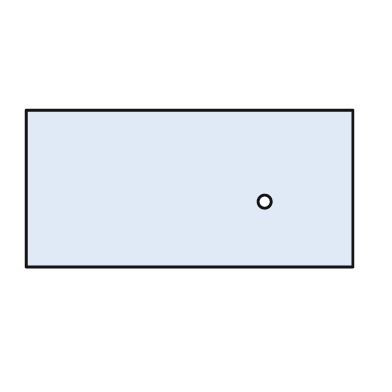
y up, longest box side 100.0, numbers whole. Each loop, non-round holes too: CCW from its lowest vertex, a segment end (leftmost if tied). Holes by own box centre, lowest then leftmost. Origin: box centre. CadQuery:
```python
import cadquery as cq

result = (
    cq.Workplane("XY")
    .moveTo(-50.0, -24.0)
    .lineTo(50.0, -24.0)
    .lineTo(50.0, 24.0)
    .lineTo(-50.0, 24.0)
    .close()
    .moveTo(23.0, -4.0)
    .circle(2.0)
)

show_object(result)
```